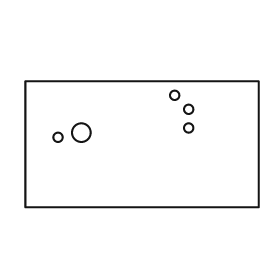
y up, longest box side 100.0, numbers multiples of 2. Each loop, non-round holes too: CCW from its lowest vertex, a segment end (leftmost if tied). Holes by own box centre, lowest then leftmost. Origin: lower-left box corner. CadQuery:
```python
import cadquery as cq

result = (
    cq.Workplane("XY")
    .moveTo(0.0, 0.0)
    .lineTo(100.0, 0.0)
    .lineTo(100.0, 54.0)
    .lineTo(0.0, 54.0)
    .close()
    .moveTo(14.0, 30.0)
    .circle(2.0)
    .moveTo(24.0, 32.0)
    .circle(4.0)
    .moveTo(70.0, 34.0)
    .circle(2.0)
    .moveTo(70.0, 42.0)
    .circle(2.0)
    .moveTo(64.0, 48.0)
    .circle(2.0)
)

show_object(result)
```